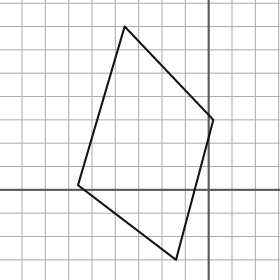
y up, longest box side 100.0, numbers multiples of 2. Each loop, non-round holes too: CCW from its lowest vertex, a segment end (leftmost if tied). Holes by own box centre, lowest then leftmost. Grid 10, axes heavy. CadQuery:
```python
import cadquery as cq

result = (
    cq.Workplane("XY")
    .moveTo(-14.0, -30.0)
    .lineTo(2.0, 30.0)
    .lineTo(-36.0, 70.0)
    .lineTo(-56.0, 2.0)
    .close()
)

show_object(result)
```